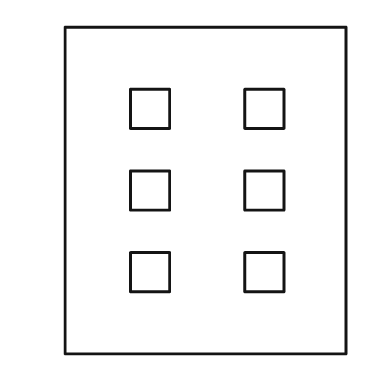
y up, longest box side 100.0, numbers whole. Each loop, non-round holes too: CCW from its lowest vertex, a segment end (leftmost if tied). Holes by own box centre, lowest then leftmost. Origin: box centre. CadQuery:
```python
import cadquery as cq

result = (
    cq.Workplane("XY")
    .moveTo(-43.0, -50.0)
    .lineTo(43.0, -50.0)
    .lineTo(43.0, 50.0)
    .lineTo(-43.0, 50.0)
    .close()
    .moveTo(-23.0, -31.0)
    .lineTo(-11.0, -31.0)
    .lineTo(-11.0, -19.0)
    .lineTo(-23.0, -19.0)
    .close()
    .moveTo(12.0, -31.0)
    .lineTo(24.0, -31.0)
    .lineTo(24.0, -19.0)
    .lineTo(12.0, -19.0)
    .close()
    .moveTo(-23.0, -6.0)
    .lineTo(-11.0, -6.0)
    .lineTo(-11.0, 6.0)
    .lineTo(-23.0, 6.0)
    .close()
    .moveTo(12.0, -6.0)
    .lineTo(24.0, -6.0)
    .lineTo(24.0, 6.0)
    .lineTo(12.0, 6.0)
    .close()
    .moveTo(-23.0, 19.0)
    .lineTo(-11.0, 19.0)
    .lineTo(-11.0, 31.0)
    .lineTo(-23.0, 31.0)
    .close()
    .moveTo(12.0, 19.0)
    .lineTo(24.0, 19.0)
    .lineTo(24.0, 31.0)
    .lineTo(12.0, 31.0)
    .close()
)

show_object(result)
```